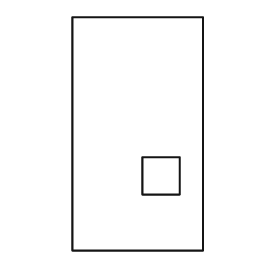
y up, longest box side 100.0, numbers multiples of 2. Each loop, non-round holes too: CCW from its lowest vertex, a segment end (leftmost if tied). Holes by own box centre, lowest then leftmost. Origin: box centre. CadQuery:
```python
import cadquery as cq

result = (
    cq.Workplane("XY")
    .moveTo(-28.0, -50.0)
    .lineTo(28.0, -50.0)
    .lineTo(28.0, 50.0)
    .lineTo(-28.0, 50.0)
    .close()
    .moveTo(2.0, -26.0)
    .lineTo(18.0, -26.0)
    .lineTo(18.0, -10.0)
    .lineTo(2.0, -10.0)
    .close()
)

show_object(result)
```